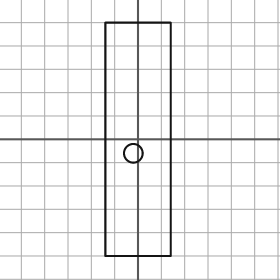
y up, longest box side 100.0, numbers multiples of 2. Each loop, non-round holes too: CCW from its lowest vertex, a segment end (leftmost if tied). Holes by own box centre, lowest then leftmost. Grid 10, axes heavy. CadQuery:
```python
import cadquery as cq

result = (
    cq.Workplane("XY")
    .moveTo(-14.0, -50.0)
    .lineTo(14.0, -50.0)
    .lineTo(14.0, 50.0)
    .lineTo(-14.0, 50.0)
    .close()
    .moveTo(-2.0, -6.0)
    .circle(4.0)
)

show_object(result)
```